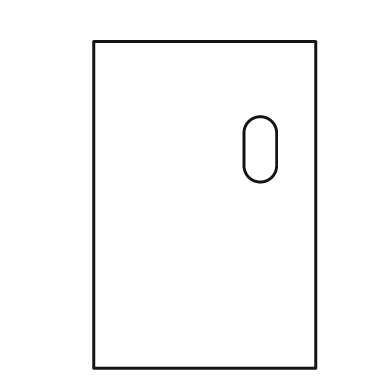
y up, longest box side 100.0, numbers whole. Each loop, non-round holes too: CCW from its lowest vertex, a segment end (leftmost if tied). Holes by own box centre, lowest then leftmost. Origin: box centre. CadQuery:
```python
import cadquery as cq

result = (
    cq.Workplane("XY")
    .moveTo(-34.0, -50.0)
    .lineTo(34.0, -50.0)
    .lineTo(34.0, 50.0)
    .lineTo(-34.0, 50.0)
    .close()
    .moveTo(12.0, 12.0)
    .threePointArc((17.0, 7.0), (22.0, 12.0))
    .lineTo(22.0, 22.0)
    .threePointArc((17.0, 27.0), (12.0, 22.0))
    .close()
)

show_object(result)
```